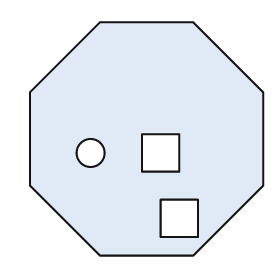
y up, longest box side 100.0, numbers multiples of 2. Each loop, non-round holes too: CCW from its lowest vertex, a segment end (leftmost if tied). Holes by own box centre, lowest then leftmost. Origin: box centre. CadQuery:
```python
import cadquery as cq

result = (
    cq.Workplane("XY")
    .moveTo(-20.0, -50.0)
    .lineTo(20.0, -50.0)
    .lineTo(50.0, -20.0)
    .lineTo(50.0, 20.0)
    .lineTo(20.0, 50.0)
    .lineTo(-20.0, 50.0)
    .lineTo(-50.0, 20.0)
    .lineTo(-50.0, -20.0)
    .close()
    .moveTo(6.0, -42.0)
    .lineTo(22.0, -42.0)
    .lineTo(22.0, -26.0)
    .lineTo(6.0, -26.0)
    .close()
    .moveTo(-24.0, -6.0)
    .circle(6.0)
    .moveTo(-2.0, -14.0)
    .lineTo(14.0, -14.0)
    .lineTo(14.0, 2.0)
    .lineTo(-2.0, 2.0)
    .close()
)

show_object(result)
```